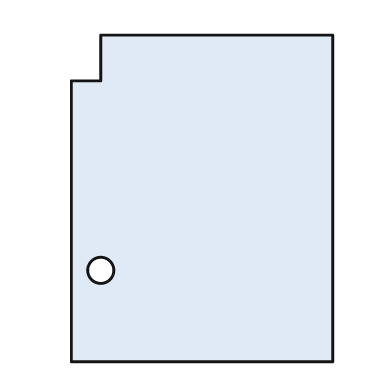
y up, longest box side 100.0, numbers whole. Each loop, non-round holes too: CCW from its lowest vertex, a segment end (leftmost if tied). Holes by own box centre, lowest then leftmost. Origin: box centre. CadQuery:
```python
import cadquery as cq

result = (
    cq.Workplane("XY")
    .moveTo(-40.0, -50.0)
    .lineTo(40.0, -50.0)
    .lineTo(40.0, 50.0)
    .lineTo(-31.0, 50.0)
    .lineTo(-31.0, 36.0)
    .lineTo(-40.0, 36.0)
    .close()
    .moveTo(-31.0, -22.0)
    .circle(4.0)
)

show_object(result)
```